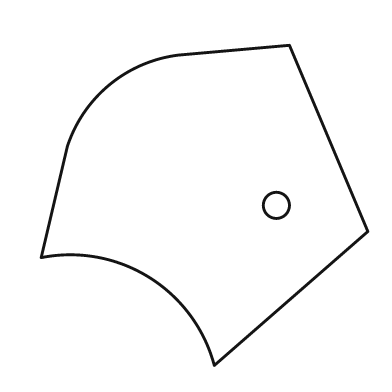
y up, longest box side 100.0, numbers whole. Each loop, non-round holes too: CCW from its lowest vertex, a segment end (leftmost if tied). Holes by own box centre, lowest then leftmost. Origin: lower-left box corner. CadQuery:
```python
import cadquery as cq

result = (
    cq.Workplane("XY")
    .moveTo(53.0, 0.0)
    .lineTo(100.0, 41.0)
    .lineTo(76.0, 98.0)
    .lineTo(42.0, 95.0)
    .threePointArc((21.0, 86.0), (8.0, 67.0))
    .lineTo(0.0, 33.0)
    .threePointArc((33.0, 27.0), (53.0, 0.0))
    .close()
    .moveTo(72.0, 49.0)
    .circle(4.0)
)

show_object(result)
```